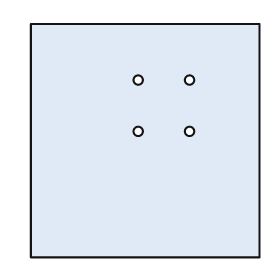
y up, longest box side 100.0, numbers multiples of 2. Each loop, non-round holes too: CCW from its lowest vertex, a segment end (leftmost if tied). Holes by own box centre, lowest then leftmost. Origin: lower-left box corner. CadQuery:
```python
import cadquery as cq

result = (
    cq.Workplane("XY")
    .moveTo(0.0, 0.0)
    .lineTo(98.0, 0.0)
    .lineTo(98.0, 100.0)
    .lineTo(0.0, 100.0)
    .close()
    .moveTo(46.0, 54.0)
    .circle(2.0)
    .moveTo(68.0, 54.0)
    .circle(2.0)
    .moveTo(46.0, 76.0)
    .circle(2.0)
    .moveTo(68.0, 76.0)
    .circle(2.0)
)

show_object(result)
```